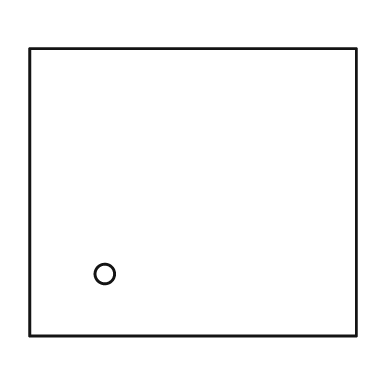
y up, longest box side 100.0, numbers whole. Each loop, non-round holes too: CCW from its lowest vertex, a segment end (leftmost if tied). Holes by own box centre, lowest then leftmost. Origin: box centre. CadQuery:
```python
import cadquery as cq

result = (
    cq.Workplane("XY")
    .moveTo(-50.0, -44.0)
    .lineTo(50.0, -44.0)
    .lineTo(50.0, 44.0)
    .lineTo(-50.0, 44.0)
    .close()
    .moveTo(-27.0, -25.0)
    .circle(3.0)
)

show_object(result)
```